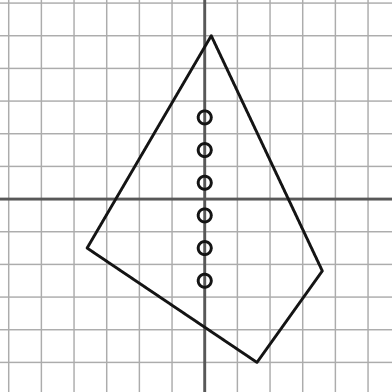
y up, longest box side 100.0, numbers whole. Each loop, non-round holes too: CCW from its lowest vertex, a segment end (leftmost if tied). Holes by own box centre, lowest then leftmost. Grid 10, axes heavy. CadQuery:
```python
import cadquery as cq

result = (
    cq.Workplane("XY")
    .moveTo(16.0, -50.0)
    .lineTo(36.0, -22.0)
    .lineTo(2.0, 50.0)
    .lineTo(-36.0, -15.0)
    .close()
    .moveTo(0.0, -25.0)
    .circle(2.0)
    .moveTo(0.0, -15.0)
    .circle(2.0)
    .moveTo(0.0, -5.0)
    .circle(2.0)
    .moveTo(0.0, 5.0)
    .circle(2.0)
    .moveTo(0.0, 15.0)
    .circle(2.0)
    .moveTo(0.0, 25.0)
    .circle(2.0)
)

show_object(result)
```